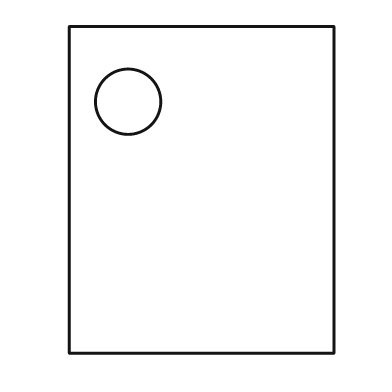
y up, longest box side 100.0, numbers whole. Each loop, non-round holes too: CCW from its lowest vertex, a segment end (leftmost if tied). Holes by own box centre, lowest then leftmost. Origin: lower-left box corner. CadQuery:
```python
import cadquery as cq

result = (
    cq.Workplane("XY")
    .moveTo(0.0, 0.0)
    .lineTo(81.0, 0.0)
    .lineTo(81.0, 100.0)
    .lineTo(0.0, 100.0)
    .close()
    .moveTo(18.0, 77.0)
    .circle(10.0)
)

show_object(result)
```